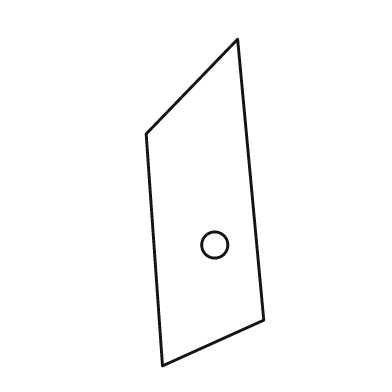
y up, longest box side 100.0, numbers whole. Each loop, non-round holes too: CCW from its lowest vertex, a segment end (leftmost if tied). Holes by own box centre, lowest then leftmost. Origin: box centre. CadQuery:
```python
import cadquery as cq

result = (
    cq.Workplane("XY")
    .moveTo(-13.0, -50.0)
    .lineTo(18.0, -36.0)
    .lineTo(10.0, 50.0)
    .lineTo(-18.0, 21.0)
    .close()
    .moveTo(3.0, -13.0)
    .circle(4.0)
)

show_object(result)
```